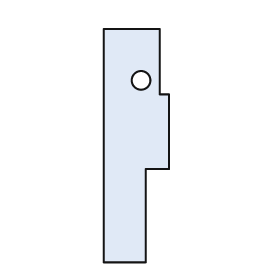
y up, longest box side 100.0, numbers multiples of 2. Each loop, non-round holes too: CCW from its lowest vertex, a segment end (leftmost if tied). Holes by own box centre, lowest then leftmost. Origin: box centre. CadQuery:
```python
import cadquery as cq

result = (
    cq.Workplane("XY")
    .moveTo(-14.0, -50.0)
    .lineTo(4.0, -50.0)
    .lineTo(4.0, -10.0)
    .lineTo(14.0, -10.0)
    .lineTo(14.0, 22.0)
    .lineTo(10.0, 22.0)
    .lineTo(10.0, 50.0)
    .lineTo(-14.0, 50.0)
    .close()
    .moveTo(2.0, 28.0)
    .circle(4.0)
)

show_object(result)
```